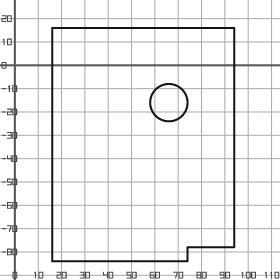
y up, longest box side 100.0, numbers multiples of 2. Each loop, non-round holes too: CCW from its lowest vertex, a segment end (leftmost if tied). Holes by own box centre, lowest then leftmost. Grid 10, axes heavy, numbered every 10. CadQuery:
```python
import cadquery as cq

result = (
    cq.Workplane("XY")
    .moveTo(16.0, -84.0)
    .lineTo(74.0, -84.0)
    .lineTo(74.0, -78.0)
    .lineTo(94.0, -78.0)
    .lineTo(94.0, 16.0)
    .lineTo(16.0, 16.0)
    .close()
    .moveTo(66.0, -16.0)
    .circle(8.0)
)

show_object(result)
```